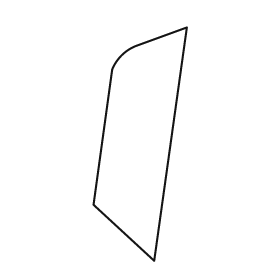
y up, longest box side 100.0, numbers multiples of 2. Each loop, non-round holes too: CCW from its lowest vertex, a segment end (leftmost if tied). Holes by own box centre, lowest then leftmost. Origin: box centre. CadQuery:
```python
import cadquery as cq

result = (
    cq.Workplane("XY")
    .moveTo(6.0, -50.0)
    .lineTo(20.0, 50.0)
    .lineTo(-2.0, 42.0)
    .threePointArc((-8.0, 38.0), (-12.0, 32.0))
    .lineTo(-20.0, -26.0)
    .close()
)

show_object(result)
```